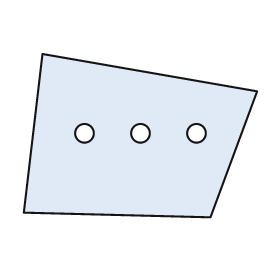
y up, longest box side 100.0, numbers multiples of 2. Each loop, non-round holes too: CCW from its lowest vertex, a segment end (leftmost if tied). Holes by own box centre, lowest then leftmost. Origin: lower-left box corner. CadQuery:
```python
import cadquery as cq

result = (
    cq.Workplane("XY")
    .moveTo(80.0, 0.0)
    .lineTo(100.0, 54.0)
    .lineTo(8.0, 70.0)
    .lineTo(0.0, 2.0)
    .close()
    .moveTo(26.0, 36.0)
    .circle(4.0)
    .moveTo(50.0, 36.0)
    .circle(4.0)
    .moveTo(74.0, 36.0)
    .circle(4.0)
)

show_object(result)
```